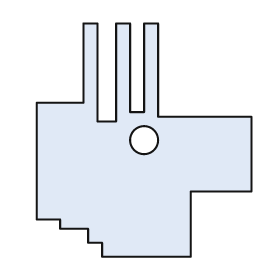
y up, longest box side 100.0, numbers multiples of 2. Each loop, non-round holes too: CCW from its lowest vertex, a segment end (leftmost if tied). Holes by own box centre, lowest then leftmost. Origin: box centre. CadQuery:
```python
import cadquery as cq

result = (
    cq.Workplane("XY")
    .moveTo(-18.0, -50.0)
    .lineTo(20.0, -50.0)
    .lineTo(20.0, -22.0)
    .lineTo(46.0, -22.0)
    .lineTo(46.0, 10.0)
    .lineTo(6.0, 10.0)
    .lineTo(6.0, 50.0)
    .lineTo(0.0, 50.0)
    .lineTo(0.0, 12.0)
    .lineTo(-6.0, 12.0)
    .lineTo(-6.0, 50.0)
    .lineTo(-12.0, 50.0)
    .lineTo(-12.0, 8.0)
    .lineTo(-20.0, 8.0)
    .lineTo(-20.0, 50.0)
    .lineTo(-26.0, 50.0)
    .lineTo(-26.0, 16.0)
    .lineTo(-46.0, 16.0)
    .lineTo(-46.0, -34.0)
    .lineTo(-36.0, -34.0)
    .lineTo(-36.0, -38.0)
    .lineTo(-24.0, -38.0)
    .lineTo(-24.0, -44.0)
    .lineTo(-18.0, -44.0)
    .close()
    .moveTo(0.0, 0.0)
    .circle(6.0)
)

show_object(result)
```